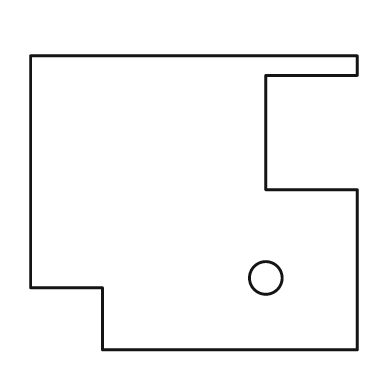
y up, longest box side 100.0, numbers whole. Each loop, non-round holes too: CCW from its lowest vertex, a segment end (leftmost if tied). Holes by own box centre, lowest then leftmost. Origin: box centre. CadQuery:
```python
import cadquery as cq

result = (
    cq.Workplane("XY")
    .moveTo(-28.0, -45.0)
    .lineTo(50.0, -45.0)
    .lineTo(50.0, 4.0)
    .lineTo(22.0, 4.0)
    .lineTo(22.0, 39.0)
    .lineTo(50.0, 39.0)
    .lineTo(50.0, 45.0)
    .lineTo(-50.0, 45.0)
    .lineTo(-50.0, -26.0)
    .lineTo(-28.0, -26.0)
    .close()
    .moveTo(22.0, -23.0)
    .circle(5.0)
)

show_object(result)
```